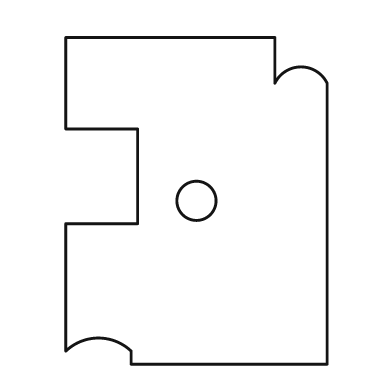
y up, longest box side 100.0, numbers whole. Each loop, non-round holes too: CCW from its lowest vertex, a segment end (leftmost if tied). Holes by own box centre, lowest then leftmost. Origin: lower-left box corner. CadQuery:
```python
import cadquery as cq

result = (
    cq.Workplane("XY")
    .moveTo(20.0, 0.0)
    .lineTo(80.0, 0.0)
    .lineTo(80.0, 86.0)
    .threePointArc((72.0, 91.0), (64.0, 86.0))
    .lineTo(64.0, 100.0)
    .lineTo(0.0, 100.0)
    .lineTo(0.0, 72.0)
    .lineTo(22.0, 72.0)
    .lineTo(22.0, 43.0)
    .lineTo(0.0, 43.0)
    .lineTo(0.0, 4.0)
    .threePointArc((10.0, 8.0), (20.0, 4.0))
    .close()
    .moveTo(40.0, 50.0)
    .circle(6.0)
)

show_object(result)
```